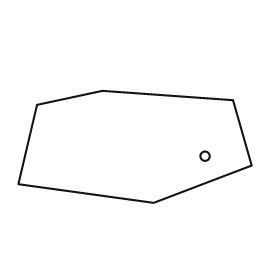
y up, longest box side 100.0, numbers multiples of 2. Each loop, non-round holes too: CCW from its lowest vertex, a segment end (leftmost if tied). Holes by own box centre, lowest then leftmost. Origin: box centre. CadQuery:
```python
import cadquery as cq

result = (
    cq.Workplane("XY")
    .moveTo(8.0, -24.0)
    .lineTo(50.0, -8.0)
    .lineTo(42.0, 20.0)
    .lineTo(-14.0, 24.0)
    .lineTo(-42.0, 18.0)
    .lineTo(-50.0, -16.0)
    .close()
    .moveTo(30.0, -4.0)
    .circle(2.0)
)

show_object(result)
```